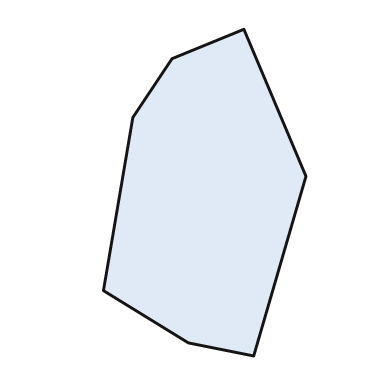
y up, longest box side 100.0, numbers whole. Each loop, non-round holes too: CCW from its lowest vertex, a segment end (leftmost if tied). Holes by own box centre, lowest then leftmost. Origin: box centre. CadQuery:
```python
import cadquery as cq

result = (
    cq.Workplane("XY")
    .moveTo(15.0, -50.0)
    .lineTo(31.0, 5.0)
    .lineTo(12.0, 50.0)
    .lineTo(-10.0, 41.0)
    .lineTo(-22.0, 23.0)
    .lineTo(-31.0, -30.0)
    .lineTo(-5.0, -46.0)
    .close()
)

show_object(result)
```